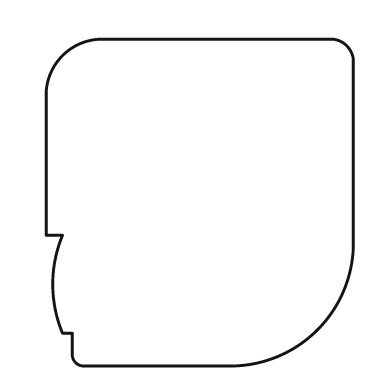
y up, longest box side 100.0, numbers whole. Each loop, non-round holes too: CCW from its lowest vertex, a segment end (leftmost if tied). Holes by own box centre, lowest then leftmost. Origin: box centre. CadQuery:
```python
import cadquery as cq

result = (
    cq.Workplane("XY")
    .moveTo(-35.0, -50.0)
    .lineTo(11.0, -50.0)
    .threePointArc((36.0, -39.0), (47.0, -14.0))
    .lineTo(47.0, 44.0)
    .threePointArc((45.0, 48.0), (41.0, 50.0))
    .lineTo(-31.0, 50.0)
    .threePointArc((-42.0, 45.0), (-47.0, 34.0))
    .lineTo(-47.0, -10.0)
    .lineTo(-42.0, -10.0)
    .threePointArc((-45.0, -25.0), (-42.0, -40.0))
    .lineTo(-39.0, -40.0)
    .lineTo(-39.0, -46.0)
    .threePointArc((-38.0, -49.0), (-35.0, -50.0))
    .close()
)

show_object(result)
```